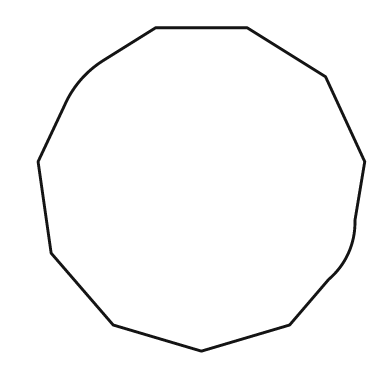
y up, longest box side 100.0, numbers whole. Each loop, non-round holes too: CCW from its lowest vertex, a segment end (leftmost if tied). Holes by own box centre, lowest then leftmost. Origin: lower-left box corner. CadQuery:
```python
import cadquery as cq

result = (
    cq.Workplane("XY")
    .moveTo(50.0, 0.0)
    .lineTo(77.0, 8.0)
    .lineTo(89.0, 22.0)
    .threePointArc((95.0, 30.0), (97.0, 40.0))
    .lineTo(100.0, 58.0)
    .lineTo(88.0, 84.0)
    .lineTo(64.0, 99.0)
    .lineTo(36.0, 99.0)
    .lineTo(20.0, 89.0)
    .threePointArc((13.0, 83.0), (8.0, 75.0))
    .lineTo(0.0, 58.0)
    .lineTo(4.0, 30.0)
    .lineTo(23.0, 8.0)
    .close()
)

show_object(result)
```